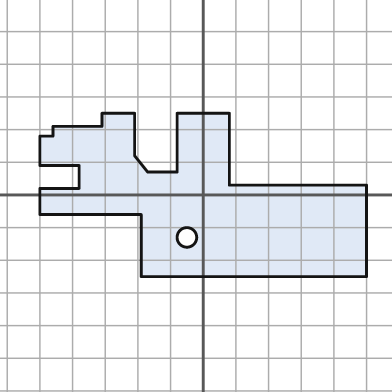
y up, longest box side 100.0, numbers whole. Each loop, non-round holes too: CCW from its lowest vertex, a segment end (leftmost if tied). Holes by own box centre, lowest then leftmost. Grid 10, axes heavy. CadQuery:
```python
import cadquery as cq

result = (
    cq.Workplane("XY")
    .moveTo(-19.0, -25.0)
    .lineTo(50.0, -25.0)
    .lineTo(50.0, 3.0)
    .lineTo(8.0, 3.0)
    .lineTo(8.0, 25.0)
    .lineTo(-8.0, 25.0)
    .lineTo(-8.0, 7.0)
    .lineTo(-17.0, 7.0)
    .lineTo(-21.0, 12.0)
    .lineTo(-21.0, 25.0)
    .lineTo(-31.0, 25.0)
    .lineTo(-31.0, 21.0)
    .lineTo(-46.0, 21.0)
    .lineTo(-46.0, 18.0)
    .lineTo(-50.0, 18.0)
    .lineTo(-50.0, 9.0)
    .lineTo(-38.0, 9.0)
    .lineTo(-38.0, 2.0)
    .lineTo(-50.0, 2.0)
    .lineTo(-50.0, -6.0)
    .lineTo(-19.0, -6.0)
    .close()
    .moveTo(-5.0, -13.0)
    .circle(3.0)
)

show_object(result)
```